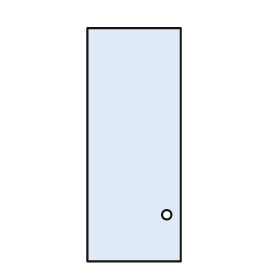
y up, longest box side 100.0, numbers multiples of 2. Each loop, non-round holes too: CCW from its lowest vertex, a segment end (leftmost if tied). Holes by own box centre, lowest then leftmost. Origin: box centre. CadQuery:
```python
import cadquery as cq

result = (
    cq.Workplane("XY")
    .moveTo(-20.0, -50.0)
    .lineTo(20.0, -50.0)
    .lineTo(20.0, 50.0)
    .lineTo(-20.0, 50.0)
    .close()
    .moveTo(14.0, -30.0)
    .circle(2.0)
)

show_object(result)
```